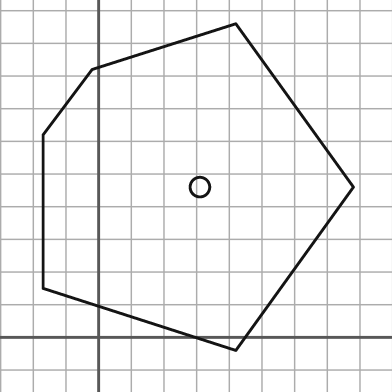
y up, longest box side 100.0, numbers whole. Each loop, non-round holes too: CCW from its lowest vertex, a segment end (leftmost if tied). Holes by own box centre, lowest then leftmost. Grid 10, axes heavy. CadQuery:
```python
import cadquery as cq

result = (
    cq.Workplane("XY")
    .moveTo(42.0, -4.0)
    .lineTo(78.0, 46.0)
    .lineTo(42.0, 96.0)
    .lineTo(-2.0, 82.0)
    .lineTo(-17.0, 62.0)
    .lineTo(-17.0, 15.0)
    .close()
    .moveTo(31.0, 46.0)
    .circle(3.0)
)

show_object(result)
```